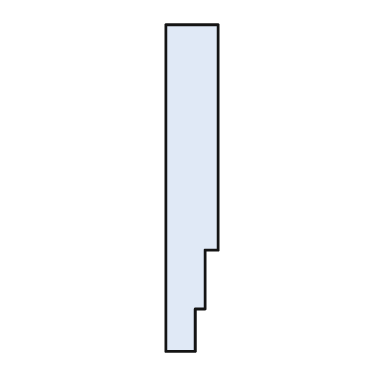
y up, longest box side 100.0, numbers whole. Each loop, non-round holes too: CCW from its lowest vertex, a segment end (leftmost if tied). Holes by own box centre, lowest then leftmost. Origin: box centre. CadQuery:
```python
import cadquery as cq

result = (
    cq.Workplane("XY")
    .moveTo(-8.0, -50.0)
    .lineTo(1.0, -50.0)
    .lineTo(1.0, -37.0)
    .lineTo(4.0, -37.0)
    .lineTo(4.0, -19.0)
    .lineTo(8.0, -19.0)
    .lineTo(8.0, 50.0)
    .lineTo(-8.0, 50.0)
    .close()
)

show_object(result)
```